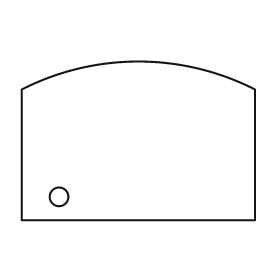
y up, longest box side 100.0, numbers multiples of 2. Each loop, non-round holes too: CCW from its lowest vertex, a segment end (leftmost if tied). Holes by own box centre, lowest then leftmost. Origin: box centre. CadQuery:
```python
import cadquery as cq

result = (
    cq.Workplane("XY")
    .moveTo(-50.0, -34.0)
    .lineTo(50.0, -34.0)
    .lineTo(50.0, 22.0)
    .threePointArc((0.0, 34.0), (-50.0, 22.0))
    .close()
    .moveTo(-34.0, -24.0)
    .circle(4.0)
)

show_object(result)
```